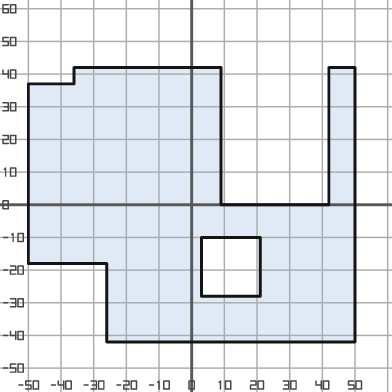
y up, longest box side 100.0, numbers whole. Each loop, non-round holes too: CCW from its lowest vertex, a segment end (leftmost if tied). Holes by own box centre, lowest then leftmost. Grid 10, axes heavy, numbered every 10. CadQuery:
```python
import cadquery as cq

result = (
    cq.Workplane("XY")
    .moveTo(-26.0, -42.0)
    .lineTo(50.0, -42.0)
    .lineTo(50.0, 42.0)
    .lineTo(42.0, 42.0)
    .lineTo(42.0, 0.0)
    .lineTo(9.0, 0.0)
    .lineTo(9.0, 42.0)
    .lineTo(-36.0, 42.0)
    .lineTo(-36.0, 37.0)
    .lineTo(-50.0, 37.0)
    .lineTo(-50.0, -18.0)
    .lineTo(-26.0, -18.0)
    .close()
    .moveTo(3.0, -28.0)
    .lineTo(21.0, -28.0)
    .lineTo(21.0, -10.0)
    .lineTo(3.0, -10.0)
    .close()
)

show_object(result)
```